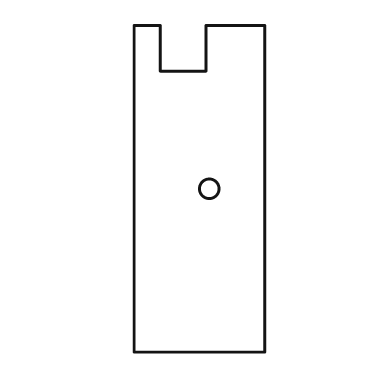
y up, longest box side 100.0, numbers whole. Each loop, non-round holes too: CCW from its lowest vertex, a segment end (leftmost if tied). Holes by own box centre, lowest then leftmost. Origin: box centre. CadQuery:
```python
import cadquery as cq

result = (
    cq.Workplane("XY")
    .moveTo(-20.0, -50.0)
    .lineTo(20.0, -50.0)
    .lineTo(20.0, 50.0)
    .lineTo(2.0, 50.0)
    .lineTo(2.0, 36.0)
    .lineTo(-12.0, 36.0)
    .lineTo(-12.0, 50.0)
    .lineTo(-20.0, 50.0)
    .close()
    .moveTo(3.0, 0.0)
    .circle(3.0)
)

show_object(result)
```